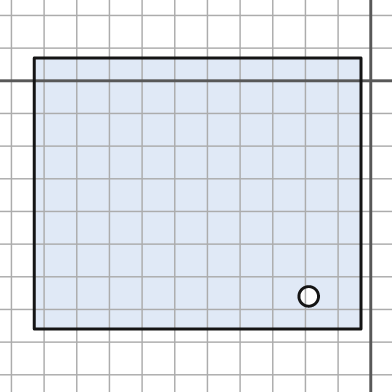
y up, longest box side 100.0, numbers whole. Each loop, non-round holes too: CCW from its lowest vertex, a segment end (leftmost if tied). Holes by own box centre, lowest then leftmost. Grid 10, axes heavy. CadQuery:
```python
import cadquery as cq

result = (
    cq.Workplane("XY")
    .moveTo(-103.0, -76.0)
    .lineTo(-3.0, -76.0)
    .lineTo(-3.0, 7.0)
    .lineTo(-103.0, 7.0)
    .close()
    .moveTo(-19.0, -66.0)
    .circle(3.0)
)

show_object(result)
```